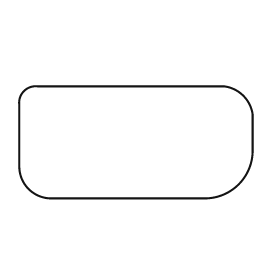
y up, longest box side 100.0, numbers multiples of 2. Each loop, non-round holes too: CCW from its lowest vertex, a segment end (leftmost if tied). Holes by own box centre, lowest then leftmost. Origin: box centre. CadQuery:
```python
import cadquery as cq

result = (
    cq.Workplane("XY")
    .moveTo(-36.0, -24.0)
    .lineTo(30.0, -24.0)
    .threePointArc((44.0, -18.0), (50.0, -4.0))
    .lineTo(50.0, 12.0)
    .threePointArc((46.0, 20.0), (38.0, 24.0))
    .lineTo(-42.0, 24.0)
    .threePointArc((-48.0, 22.0), (-50.0, 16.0))
    .lineTo(-50.0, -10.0)
    .threePointArc((-46.0, -20.0), (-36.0, -24.0))
    .close()
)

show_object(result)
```